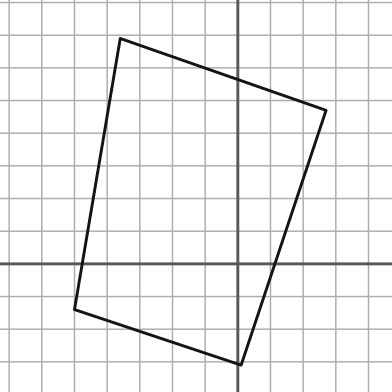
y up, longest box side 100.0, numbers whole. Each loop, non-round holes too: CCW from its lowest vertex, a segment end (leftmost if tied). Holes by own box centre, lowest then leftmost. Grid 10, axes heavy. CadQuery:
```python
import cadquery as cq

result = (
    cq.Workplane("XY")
    .moveTo(1.0, -31.0)
    .lineTo(27.0, 47.0)
    .lineTo(-36.0, 69.0)
    .lineTo(-50.0, -14.0)
    .close()
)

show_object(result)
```